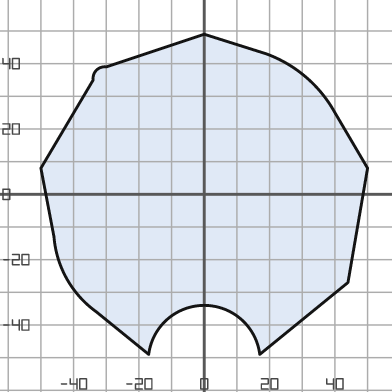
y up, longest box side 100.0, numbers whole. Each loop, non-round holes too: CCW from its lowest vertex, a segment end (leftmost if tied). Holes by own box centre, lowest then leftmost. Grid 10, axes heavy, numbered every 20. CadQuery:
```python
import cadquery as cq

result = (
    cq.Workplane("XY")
    .moveTo(-17.0, -49.0)
    .threePointArc((0.0, -34.0), (17.0, -49.0))
    .lineTo(44.0, -27.0)
    .lineTo(50.0, 8.0)
    .lineTo(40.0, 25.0)
    .threePointArc((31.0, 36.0), (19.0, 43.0))
    .lineTo(0.0, 49.0)
    .lineTo(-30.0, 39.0)
    .threePointArc((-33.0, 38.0), (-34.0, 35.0))
    .lineTo(-50.0, 8.0)
    .lineTo(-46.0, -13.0)
    .threePointArc((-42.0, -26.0), (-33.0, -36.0))
    .close()
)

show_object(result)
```